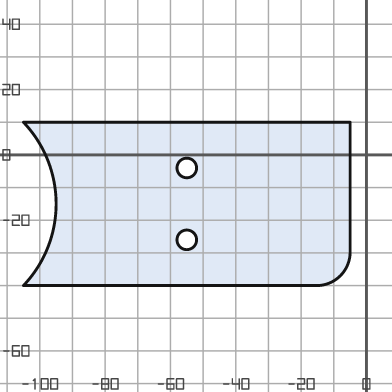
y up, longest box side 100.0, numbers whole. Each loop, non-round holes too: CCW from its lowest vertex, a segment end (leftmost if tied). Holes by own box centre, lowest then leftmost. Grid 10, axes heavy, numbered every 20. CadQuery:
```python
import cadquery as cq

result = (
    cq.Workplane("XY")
    .moveTo(-105.0, -40.0)
    .lineTo(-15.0, -40.0)
    .threePointArc((-8.0, -37.0), (-5.0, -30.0))
    .lineTo(-5.0, 10.0)
    .lineTo(-105.0, 10.0)
    .threePointArc((-95.0, -15.0), (-105.0, -40.0))
    .close()
    .moveTo(-55.0, -26.0)
    .circle(3.0)
    .moveTo(-55.0, -4.0)
    .circle(3.0)
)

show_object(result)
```